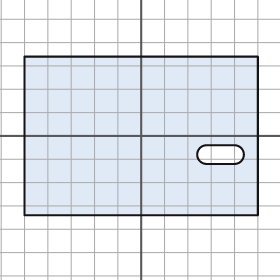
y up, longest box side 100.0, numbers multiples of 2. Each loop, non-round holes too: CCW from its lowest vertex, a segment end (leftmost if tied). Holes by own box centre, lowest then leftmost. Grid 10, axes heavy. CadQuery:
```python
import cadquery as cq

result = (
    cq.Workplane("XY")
    .moveTo(-50.0, -34.0)
    .lineTo(50.0, -34.0)
    .lineTo(50.0, 34.0)
    .lineTo(-50.0, 34.0)
    .close()
    .moveTo(28.0, -12.0)
    .lineTo(40.0, -12.0)
    .threePointArc((44.0, -8.0), (40.0, -4.0))
    .lineTo(28.0, -4.0)
    .threePointArc((24.0, -8.0), (28.0, -12.0))
    .close()
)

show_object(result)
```